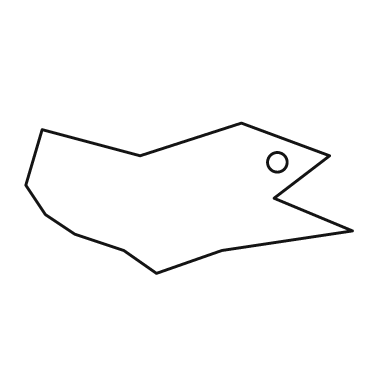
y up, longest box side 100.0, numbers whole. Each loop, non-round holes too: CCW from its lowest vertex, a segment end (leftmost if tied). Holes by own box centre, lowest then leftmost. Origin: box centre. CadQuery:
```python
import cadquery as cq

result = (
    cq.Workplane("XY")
    .moveTo(-10.0, -23.0)
    .lineTo(10.0, -16.0)
    .lineTo(50.0, -10.0)
    .lineTo(26.0, 0.0)
    .lineTo(43.0, 13.0)
    .lineTo(16.0, 23.0)
    .lineTo(-15.0, 13.0)
    .lineTo(-45.0, 21.0)
    .lineTo(-50.0, 4.0)
    .lineTo(-44.0, -5.0)
    .lineTo(-35.0, -11.0)
    .lineTo(-20.0, -16.0)
    .close()
    .moveTo(27.0, 11.0)
    .circle(3.0)
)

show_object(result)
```